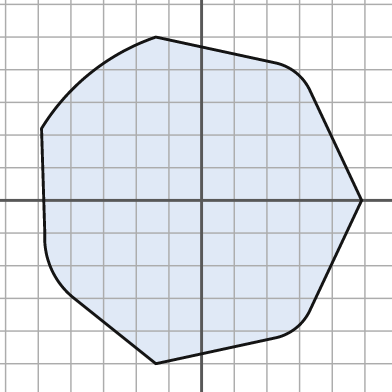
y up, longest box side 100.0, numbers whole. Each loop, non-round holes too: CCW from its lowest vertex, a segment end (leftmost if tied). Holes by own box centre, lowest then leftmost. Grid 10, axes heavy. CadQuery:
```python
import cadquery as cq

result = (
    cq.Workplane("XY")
    .moveTo(-14.0, -50.0)
    .lineTo(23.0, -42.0)
    .threePointArc((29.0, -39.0), (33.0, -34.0))
    .lineTo(49.0, 0.0)
    .lineTo(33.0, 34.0)
    .threePointArc((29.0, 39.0), (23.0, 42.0))
    .lineTo(-14.0, 50.0)
    .threePointArc((-34.0, 39.0), (-49.0, 22.0))
    .lineTo(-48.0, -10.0)
    .threePointArc((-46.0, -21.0), (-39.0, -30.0))
    .close()
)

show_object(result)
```